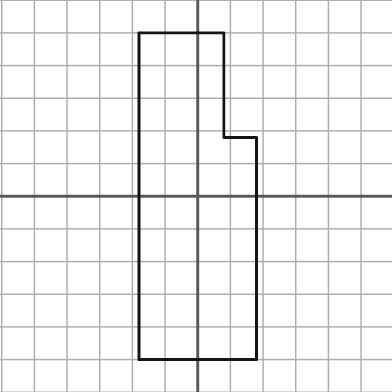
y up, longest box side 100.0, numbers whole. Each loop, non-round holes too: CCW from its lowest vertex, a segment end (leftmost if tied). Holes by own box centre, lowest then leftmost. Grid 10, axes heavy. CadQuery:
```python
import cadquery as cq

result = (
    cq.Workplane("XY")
    .moveTo(-18.0, -50.0)
    .lineTo(18.0, -50.0)
    .lineTo(18.0, 18.0)
    .lineTo(8.0, 18.0)
    .lineTo(8.0, 50.0)
    .lineTo(-18.0, 50.0)
    .close()
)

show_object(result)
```